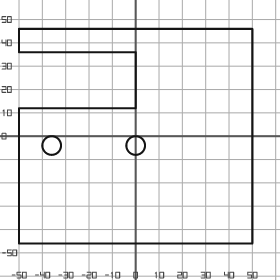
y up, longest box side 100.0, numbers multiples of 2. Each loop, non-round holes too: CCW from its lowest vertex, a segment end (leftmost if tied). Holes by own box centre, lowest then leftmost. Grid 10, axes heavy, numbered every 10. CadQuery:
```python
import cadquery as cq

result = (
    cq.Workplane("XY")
    .moveTo(-50.0, -46.0)
    .lineTo(50.0, -46.0)
    .lineTo(50.0, 46.0)
    .lineTo(-50.0, 46.0)
    .lineTo(-50.0, 36.0)
    .lineTo(0.0, 36.0)
    .lineTo(0.0, 12.0)
    .lineTo(-50.0, 12.0)
    .close()
    .moveTo(-36.0, -4.0)
    .circle(4.0)
    .moveTo(0.0, -4.0)
    .circle(4.0)
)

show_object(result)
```